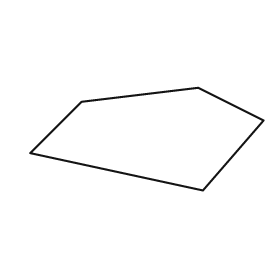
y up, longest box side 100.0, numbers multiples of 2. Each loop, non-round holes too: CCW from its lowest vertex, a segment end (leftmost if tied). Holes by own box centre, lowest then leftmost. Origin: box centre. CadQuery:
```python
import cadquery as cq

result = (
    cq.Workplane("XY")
    .moveTo(24.0, -22.0)
    .lineTo(50.0, 8.0)
    .lineTo(22.0, 22.0)
    .lineTo(-28.0, 16.0)
    .lineTo(-50.0, -6.0)
    .close()
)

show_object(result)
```